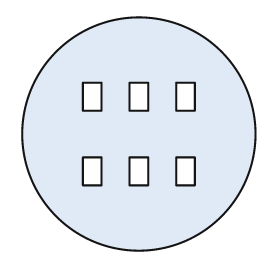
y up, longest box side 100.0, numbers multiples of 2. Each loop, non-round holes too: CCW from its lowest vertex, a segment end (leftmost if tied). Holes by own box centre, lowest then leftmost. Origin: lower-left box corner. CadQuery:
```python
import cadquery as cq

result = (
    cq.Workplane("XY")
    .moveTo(50.0, 50.0)
    .circle(50.0)
    .moveTo(26.0, 28.0)
    .lineTo(34.0, 28.0)
    .lineTo(34.0, 40.0)
    .lineTo(26.0, 40.0)
    .close()
    .moveTo(46.0, 28.0)
    .lineTo(54.0, 28.0)
    .lineTo(54.0, 40.0)
    .lineTo(46.0, 40.0)
    .close()
    .moveTo(66.0, 28.0)
    .lineTo(74.0, 28.0)
    .lineTo(74.0, 40.0)
    .lineTo(66.0, 40.0)
    .close()
    .moveTo(26.0, 60.0)
    .lineTo(34.0, 60.0)
    .lineTo(34.0, 72.0)
    .lineTo(26.0, 72.0)
    .close()
    .moveTo(46.0, 60.0)
    .lineTo(54.0, 60.0)
    .lineTo(54.0, 72.0)
    .lineTo(46.0, 72.0)
    .close()
    .moveTo(66.0, 60.0)
    .lineTo(74.0, 60.0)
    .lineTo(74.0, 72.0)
    .lineTo(66.0, 72.0)
    .close()
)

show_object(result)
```